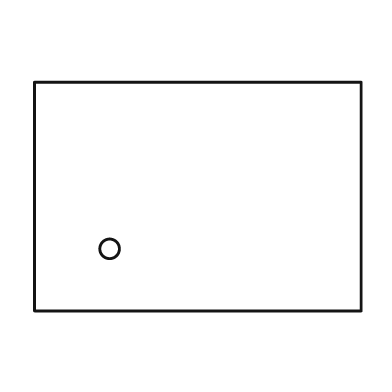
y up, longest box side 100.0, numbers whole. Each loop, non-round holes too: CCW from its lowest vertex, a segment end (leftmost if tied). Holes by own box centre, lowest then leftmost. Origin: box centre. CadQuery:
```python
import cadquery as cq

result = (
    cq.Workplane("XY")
    .moveTo(-50.0, -35.0)
    .lineTo(50.0, -35.0)
    .lineTo(50.0, 35.0)
    .lineTo(-50.0, 35.0)
    .close()
    .moveTo(-27.0, -16.0)
    .circle(3.0)
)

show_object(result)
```